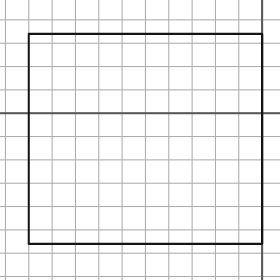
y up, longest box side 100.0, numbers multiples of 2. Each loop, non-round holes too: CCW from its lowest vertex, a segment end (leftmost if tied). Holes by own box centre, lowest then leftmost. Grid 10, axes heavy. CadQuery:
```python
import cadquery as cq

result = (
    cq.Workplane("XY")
    .moveTo(-100.0, -56.0)
    .lineTo(0.0, -56.0)
    .lineTo(0.0, 34.0)
    .lineTo(-100.0, 34.0)
    .close()
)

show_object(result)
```